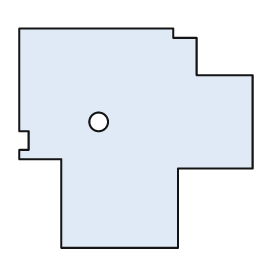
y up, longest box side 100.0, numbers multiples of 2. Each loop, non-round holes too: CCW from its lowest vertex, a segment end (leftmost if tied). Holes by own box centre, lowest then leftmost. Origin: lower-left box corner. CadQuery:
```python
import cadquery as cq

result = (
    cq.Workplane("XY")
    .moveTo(18.0, 0.0)
    .lineTo(68.0, 0.0)
    .lineTo(68.0, 34.0)
    .lineTo(100.0, 34.0)
    .lineTo(100.0, 74.0)
    .lineTo(76.0, 74.0)
    .lineTo(76.0, 90.0)
    .lineTo(66.0, 90.0)
    .lineTo(66.0, 94.0)
    .lineTo(0.0, 94.0)
    .lineTo(0.0, 50.0)
    .lineTo(4.0, 50.0)
    .lineTo(4.0, 42.0)
    .lineTo(0.0, 42.0)
    .lineTo(0.0, 38.0)
    .lineTo(18.0, 38.0)
    .close()
    .moveTo(34.0, 54.0)
    .circle(4.0)
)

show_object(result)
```